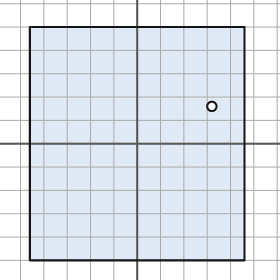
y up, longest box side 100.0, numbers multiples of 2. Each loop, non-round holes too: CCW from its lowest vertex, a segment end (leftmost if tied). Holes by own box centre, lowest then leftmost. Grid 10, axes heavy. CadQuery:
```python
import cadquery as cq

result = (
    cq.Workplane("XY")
    .moveTo(-46.0, -50.0)
    .lineTo(46.0, -50.0)
    .lineTo(46.0, 50.0)
    .lineTo(-46.0, 50.0)
    .close()
    .moveTo(32.0, 16.0)
    .circle(2.0)
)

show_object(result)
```